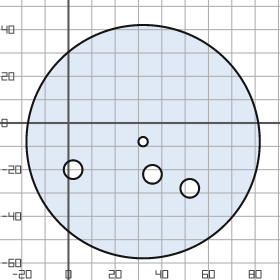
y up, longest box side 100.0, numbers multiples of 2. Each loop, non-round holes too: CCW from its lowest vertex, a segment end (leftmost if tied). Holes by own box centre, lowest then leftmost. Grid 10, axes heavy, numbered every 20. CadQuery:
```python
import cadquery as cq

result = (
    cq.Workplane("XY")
    .moveTo(32.0, -8.0)
    .circle(50.0)
    .moveTo(52.0, -28.0)
    .circle(4.0)
    .moveTo(36.0, -22.0)
    .circle(4.0)
    .moveTo(2.0, -20.0)
    .circle(4.0)
    .moveTo(32.0, -8.0)
    .circle(2.0)
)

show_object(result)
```